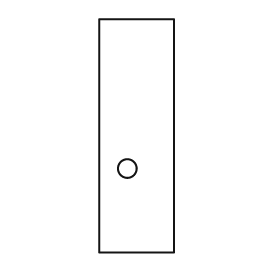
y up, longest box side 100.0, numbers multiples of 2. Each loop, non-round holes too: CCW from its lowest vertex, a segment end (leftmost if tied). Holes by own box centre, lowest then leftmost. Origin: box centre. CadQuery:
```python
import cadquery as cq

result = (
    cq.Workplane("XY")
    .moveTo(-16.0, -50.0)
    .lineTo(16.0, -50.0)
    .lineTo(16.0, 50.0)
    .lineTo(-16.0, 50.0)
    .close()
    .moveTo(-4.0, -14.0)
    .circle(4.0)
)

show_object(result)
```